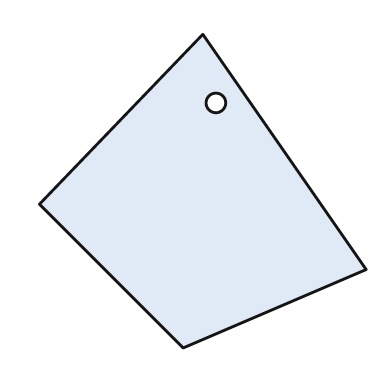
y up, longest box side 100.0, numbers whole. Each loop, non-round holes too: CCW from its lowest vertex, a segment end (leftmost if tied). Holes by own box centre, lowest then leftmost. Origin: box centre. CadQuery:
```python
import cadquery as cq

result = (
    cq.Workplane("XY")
    .moveTo(-6.0, -48.0)
    .lineTo(50.0, -24.0)
    .lineTo(0.0, 48.0)
    .lineTo(-50.0, -4.0)
    .close()
    .moveTo(4.0, 27.0)
    .circle(3.0)
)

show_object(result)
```